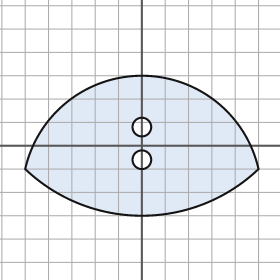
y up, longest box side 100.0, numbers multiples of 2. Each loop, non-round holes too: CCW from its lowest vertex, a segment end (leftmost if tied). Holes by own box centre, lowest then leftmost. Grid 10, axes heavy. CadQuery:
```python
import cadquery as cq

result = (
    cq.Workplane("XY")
    .moveTo(-50.0, -10.0)
    .threePointArc((0.0, -30.0), (50.0, -10.0))
    .threePointArc((0.0, 30.0), (-50.0, -10.0))
    .close()
    .moveTo(0.0, -6.0)
    .circle(4.0)
    .moveTo(0.0, 8.0)
    .circle(4.0)
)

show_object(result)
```